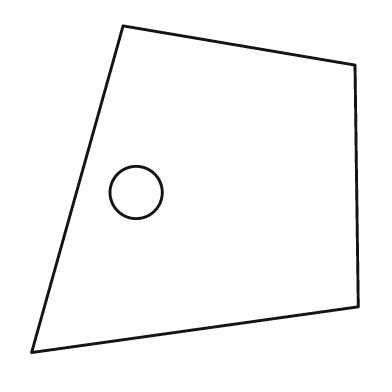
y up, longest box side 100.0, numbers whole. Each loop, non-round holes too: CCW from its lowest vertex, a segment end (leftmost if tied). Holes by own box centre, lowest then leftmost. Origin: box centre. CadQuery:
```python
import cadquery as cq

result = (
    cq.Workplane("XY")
    .moveTo(-50.0, -50.0)
    .lineTo(50.0, -36.0)
    .lineTo(49.0, 38.0)
    .lineTo(-22.0, 50.0)
    .close()
    .moveTo(-18.0, -1.0)
    .circle(8.0)
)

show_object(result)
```